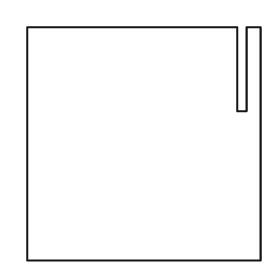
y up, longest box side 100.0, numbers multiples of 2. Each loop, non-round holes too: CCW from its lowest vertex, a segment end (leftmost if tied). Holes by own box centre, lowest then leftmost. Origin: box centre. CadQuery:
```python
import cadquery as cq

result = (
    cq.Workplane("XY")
    .moveTo(-50.0, -50.0)
    .lineTo(50.0, -50.0)
    .lineTo(50.0, 50.0)
    .lineTo(44.0, 50.0)
    .lineTo(44.0, 14.0)
    .lineTo(40.0, 14.0)
    .lineTo(40.0, 50.0)
    .lineTo(-50.0, 50.0)
    .close()
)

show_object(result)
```